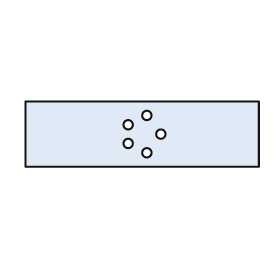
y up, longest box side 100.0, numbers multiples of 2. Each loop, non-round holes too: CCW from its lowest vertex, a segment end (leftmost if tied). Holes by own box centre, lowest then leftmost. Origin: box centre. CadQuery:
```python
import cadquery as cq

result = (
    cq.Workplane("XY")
    .moveTo(-50.0, -14.0)
    .lineTo(50.0, -14.0)
    .lineTo(50.0, 14.0)
    .lineTo(-50.0, 14.0)
    .close()
    .moveTo(2.0, -8.0)
    .circle(2.0)
    .moveTo(-6.0, -4.0)
    .circle(2.0)
    .moveTo(8.0, 0.0)
    .circle(2.0)
    .moveTo(-6.0, 4.0)
    .circle(2.0)
    .moveTo(2.0, 8.0)
    .circle(2.0)
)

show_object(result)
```